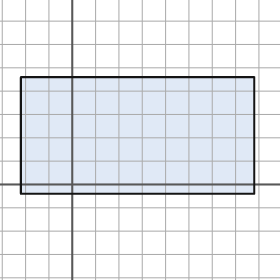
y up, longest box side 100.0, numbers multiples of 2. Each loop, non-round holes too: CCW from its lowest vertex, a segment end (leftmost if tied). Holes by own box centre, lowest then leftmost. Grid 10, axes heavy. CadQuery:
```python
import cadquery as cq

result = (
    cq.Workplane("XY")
    .moveTo(-22.0, -4.0)
    .lineTo(78.0, -4.0)
    .lineTo(78.0, 46.0)
    .lineTo(-22.0, 46.0)
    .close()
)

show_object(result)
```